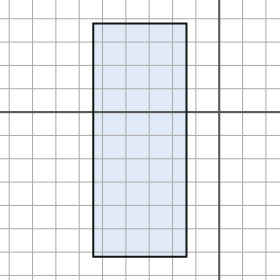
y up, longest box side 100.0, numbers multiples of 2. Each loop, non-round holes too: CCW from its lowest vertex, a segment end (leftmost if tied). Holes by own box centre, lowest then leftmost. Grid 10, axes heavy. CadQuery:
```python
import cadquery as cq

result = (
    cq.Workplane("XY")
    .moveTo(-54.0, -62.0)
    .lineTo(-14.0, -62.0)
    .lineTo(-14.0, 38.0)
    .lineTo(-54.0, 38.0)
    .close()
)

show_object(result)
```